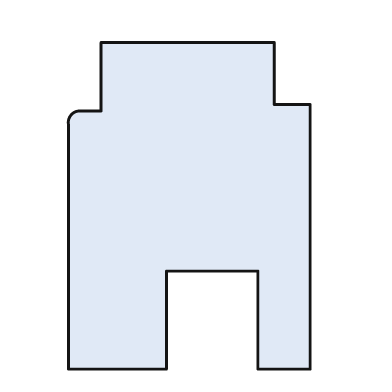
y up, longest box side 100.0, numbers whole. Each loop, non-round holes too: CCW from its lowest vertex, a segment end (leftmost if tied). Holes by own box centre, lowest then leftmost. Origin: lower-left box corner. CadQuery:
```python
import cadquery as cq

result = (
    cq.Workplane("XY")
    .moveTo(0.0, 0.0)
    .lineTo(30.0, 0.0)
    .lineTo(30.0, 30.0)
    .lineTo(58.0, 30.0)
    .lineTo(58.0, 0.0)
    .lineTo(74.0, 0.0)
    .lineTo(74.0, 81.0)
    .lineTo(63.0, 81.0)
    .lineTo(63.0, 100.0)
    .lineTo(10.0, 100.0)
    .lineTo(10.0, 79.0)
    .lineTo(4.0, 79.0)
    .threePointArc((1.0, 78.0), (0.0, 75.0))
    .close()
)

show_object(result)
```